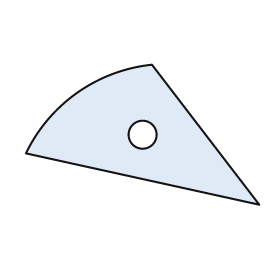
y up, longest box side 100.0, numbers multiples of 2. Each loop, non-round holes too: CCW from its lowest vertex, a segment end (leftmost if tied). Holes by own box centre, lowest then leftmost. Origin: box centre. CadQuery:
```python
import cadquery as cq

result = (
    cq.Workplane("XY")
    .moveTo(50.0, -30.0)
    .lineTo(4.0, 30.0)
    .threePointArc((-28.0, 18.0), (-50.0, -8.0))
    .close()
    .moveTo(0.0, 0.0)
    .circle(6.0)
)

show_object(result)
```